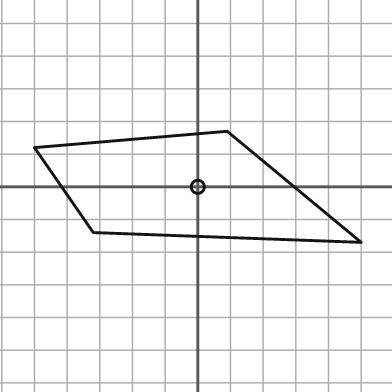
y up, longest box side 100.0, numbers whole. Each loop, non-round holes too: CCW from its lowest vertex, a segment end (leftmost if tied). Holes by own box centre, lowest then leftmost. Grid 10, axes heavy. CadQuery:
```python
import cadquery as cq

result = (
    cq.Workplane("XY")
    .moveTo(50.0, -17.0)
    .lineTo(9.0, 17.0)
    .lineTo(-50.0, 12.0)
    .lineTo(-32.0, -14.0)
    .close()
    .moveTo(0.0, 0.0)
    .circle(2.0)
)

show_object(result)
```